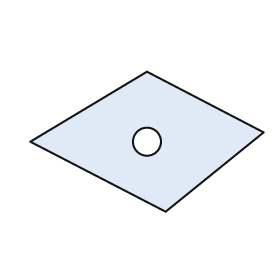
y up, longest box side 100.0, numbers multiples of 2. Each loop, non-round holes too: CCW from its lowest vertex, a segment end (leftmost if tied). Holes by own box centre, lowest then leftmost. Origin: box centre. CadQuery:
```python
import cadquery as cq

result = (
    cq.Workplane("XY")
    .moveTo(8.0, -30.0)
    .lineTo(50.0, 4.0)
    .lineTo(0.0, 30.0)
    .lineTo(-50.0, 0.0)
    .close()
    .moveTo(0.0, 0.0)
    .circle(6.0)
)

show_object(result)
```